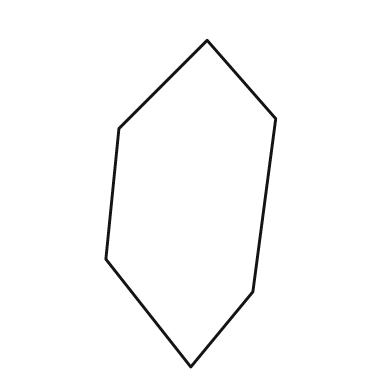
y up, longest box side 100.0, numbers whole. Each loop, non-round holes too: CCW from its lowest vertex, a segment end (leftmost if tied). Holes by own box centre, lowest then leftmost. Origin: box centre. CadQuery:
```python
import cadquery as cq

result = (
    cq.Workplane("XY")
    .moveTo(0.0, -50.0)
    .lineTo(19.0, -27.0)
    .lineTo(26.0, 26.0)
    .lineTo(5.0, 50.0)
    .lineTo(-22.0, 23.0)
    .lineTo(-26.0, -17.0)
    .close()
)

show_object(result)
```